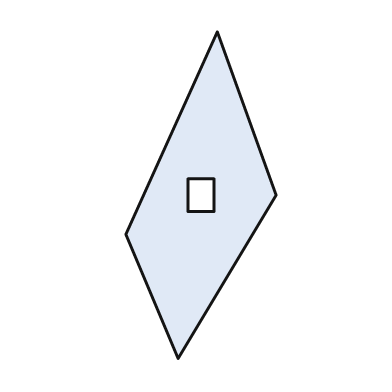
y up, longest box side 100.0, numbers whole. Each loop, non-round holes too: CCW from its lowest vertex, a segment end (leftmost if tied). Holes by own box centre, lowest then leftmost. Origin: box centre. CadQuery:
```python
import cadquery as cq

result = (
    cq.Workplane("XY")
    .moveTo(-7.0, -50.0)
    .lineTo(23.0, 0.0)
    .lineTo(5.0, 50.0)
    .lineTo(-23.0, -12.0)
    .close()
    .moveTo(-4.0, -5.0)
    .lineTo(4.0, -5.0)
    .lineTo(4.0, 5.0)
    .lineTo(-4.0, 5.0)
    .close()
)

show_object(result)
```